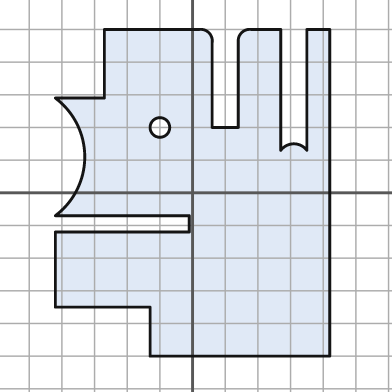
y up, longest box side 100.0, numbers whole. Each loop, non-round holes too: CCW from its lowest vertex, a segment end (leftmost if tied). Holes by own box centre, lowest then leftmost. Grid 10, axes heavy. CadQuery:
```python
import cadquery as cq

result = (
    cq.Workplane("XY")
    .moveTo(-13.0, -50.0)
    .lineTo(42.0, -50.0)
    .lineTo(42.0, 50.0)
    .lineTo(35.0, 50.0)
    .lineTo(35.0, 13.0)
    .threePointArc((31.0, 15.0), (27.0, 13.0))
    .lineTo(27.0, 50.0)
    .lineTo(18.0, 50.0)
    .threePointArc((15.0, 49.0), (14.0, 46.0))
    .lineTo(14.0, 20.0)
    .lineTo(6.0, 20.0)
    .lineTo(6.0, 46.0)
    .threePointArc((5.0, 49.0), (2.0, 50.0))
    .lineTo(-27.0, 50.0)
    .lineTo(-27.0, 29.0)
    .lineTo(-42.0, 29.0)
    .threePointArc((-33.0, 11.0), (-42.0, -7.0))
    .lineTo(-1.0, -7.0)
    .lineTo(-1.0, -12.0)
    .lineTo(-42.0, -12.0)
    .lineTo(-42.0, -35.0)
    .lineTo(-13.0, -35.0)
    .close()
    .moveTo(-10.0, 20.0)
    .circle(3.0)
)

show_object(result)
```